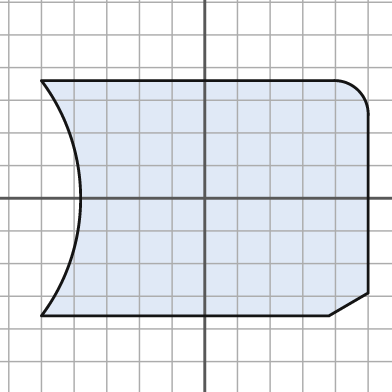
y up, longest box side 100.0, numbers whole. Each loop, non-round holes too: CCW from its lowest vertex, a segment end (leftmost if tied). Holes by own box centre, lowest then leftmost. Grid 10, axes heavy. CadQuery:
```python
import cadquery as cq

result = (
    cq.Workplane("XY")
    .moveTo(-50.0, -36.0)
    .lineTo(38.0, -36.0)
    .lineTo(50.0, -29.0)
    .lineTo(50.0, 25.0)
    .threePointArc((47.0, 33.0), (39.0, 36.0))
    .lineTo(-50.0, 36.0)
    .threePointArc((-38.0, 0.0), (-50.0, -36.0))
    .close()
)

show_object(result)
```